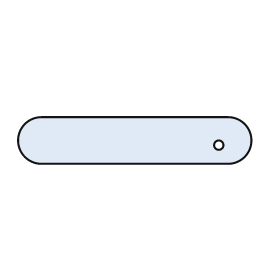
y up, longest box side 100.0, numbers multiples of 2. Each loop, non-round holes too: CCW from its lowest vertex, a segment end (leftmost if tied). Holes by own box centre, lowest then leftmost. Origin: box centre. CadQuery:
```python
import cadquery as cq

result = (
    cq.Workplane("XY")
    .moveTo(-40.0, -10.0)
    .lineTo(40.0, -10.0)
    .threePointArc((50.0, 0.0), (40.0, 10.0))
    .lineTo(-40.0, 10.0)
    .threePointArc((-50.0, 0.0), (-40.0, -10.0))
    .close()
    .moveTo(36.0, -2.0)
    .circle(2.0)
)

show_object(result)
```